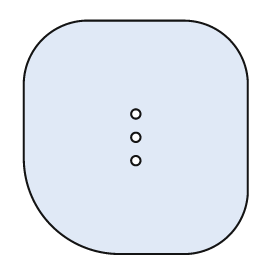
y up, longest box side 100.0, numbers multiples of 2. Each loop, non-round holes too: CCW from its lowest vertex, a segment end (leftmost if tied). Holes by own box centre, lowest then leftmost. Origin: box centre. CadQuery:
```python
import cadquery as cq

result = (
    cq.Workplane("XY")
    .moveTo(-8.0, -50.0)
    .lineTo(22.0, -50.0)
    .threePointArc((40.0, -42.0), (48.0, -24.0))
    .lineTo(48.0, 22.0)
    .threePointArc((40.0, 42.0), (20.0, 50.0))
    .lineTo(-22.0, 50.0)
    .threePointArc((-40.0, 42.0), (-48.0, 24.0))
    .lineTo(-48.0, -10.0)
    .threePointArc((-36.0, -38.0), (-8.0, -50.0))
    .close()
    .moveTo(0.0, -10.0)
    .circle(2.0)
    .moveTo(0.0, 0.0)
    .circle(2.0)
    .moveTo(0.0, 10.0)
    .circle(2.0)
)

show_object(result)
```